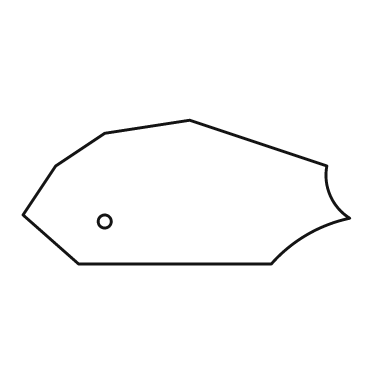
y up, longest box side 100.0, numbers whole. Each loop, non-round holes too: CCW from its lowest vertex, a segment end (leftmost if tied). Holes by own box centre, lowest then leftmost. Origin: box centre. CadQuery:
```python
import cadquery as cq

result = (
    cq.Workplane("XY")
    .moveTo(-33.0, -22.0)
    .lineTo(26.0, -22.0)
    .threePointArc((37.0, -13.0), (50.0, -8.0))
    .threePointArc((44.0, -1.0), (43.0, 8.0))
    .lineTo(1.0, 22.0)
    .lineTo(-25.0, 18.0)
    .lineTo(-40.0, 8.0)
    .lineTo(-50.0, -7.0)
    .close()
    .moveTo(-25.0, -9.0)
    .circle(2.0)
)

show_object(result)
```